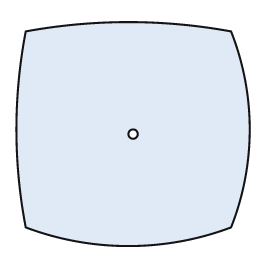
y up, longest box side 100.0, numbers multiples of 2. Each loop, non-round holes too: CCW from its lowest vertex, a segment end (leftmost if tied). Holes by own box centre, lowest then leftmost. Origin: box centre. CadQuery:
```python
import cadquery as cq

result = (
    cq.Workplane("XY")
    .moveTo(-46.0, -40.0)
    .threePointArc((-2.0, -48.0), (42.0, -40.0))
    .threePointArc((50.0, 2.0), (42.0, 44.0))
    .threePointArc((-2.0, 48.0), (-46.0, 44.0))
    .threePointArc((-50.0, 2.0), (-46.0, -40.0))
    .close()
    .moveTo(0.0, 0.0)
    .circle(2.0)
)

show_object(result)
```